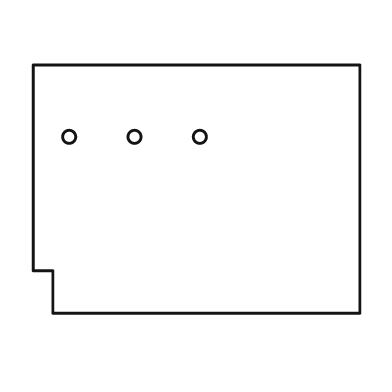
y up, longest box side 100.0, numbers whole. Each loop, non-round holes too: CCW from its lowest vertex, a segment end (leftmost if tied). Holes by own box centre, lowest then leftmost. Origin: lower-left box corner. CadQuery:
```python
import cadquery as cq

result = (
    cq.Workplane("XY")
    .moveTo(6.0, 0.0)
    .lineTo(100.0, 0.0)
    .lineTo(100.0, 76.0)
    .lineTo(0.0, 76.0)
    .lineTo(0.0, 13.0)
    .lineTo(6.0, 13.0)
    .close()
    .moveTo(11.0, 54.0)
    .circle(2.0)
    .moveTo(31.0, 54.0)
    .circle(2.0)
    .moveTo(51.0, 54.0)
    .circle(2.0)
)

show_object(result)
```